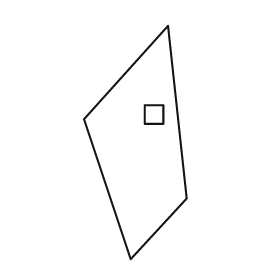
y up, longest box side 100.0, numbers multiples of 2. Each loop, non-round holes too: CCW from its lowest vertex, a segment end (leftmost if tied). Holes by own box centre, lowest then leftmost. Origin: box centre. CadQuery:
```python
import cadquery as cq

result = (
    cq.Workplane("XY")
    .moveTo(-2.0, -50.0)
    .lineTo(22.0, -24.0)
    .lineTo(14.0, 50.0)
    .lineTo(-22.0, 10.0)
    .close()
    .moveTo(4.0, 8.0)
    .lineTo(12.0, 8.0)
    .lineTo(12.0, 16.0)
    .lineTo(4.0, 16.0)
    .close()
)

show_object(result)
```